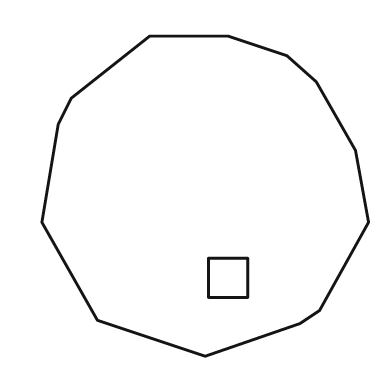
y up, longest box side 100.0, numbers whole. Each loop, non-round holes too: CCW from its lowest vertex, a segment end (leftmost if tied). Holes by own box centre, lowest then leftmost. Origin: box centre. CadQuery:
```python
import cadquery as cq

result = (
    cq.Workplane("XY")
    .moveTo(0.0, -49.0)
    .lineTo(29.0, -39.0)
    .lineTo(35.0, -35.0)
    .lineTo(50.0, -8.0)
    .lineTo(46.0, 14.0)
    .lineTo(34.0, 35.0)
    .lineTo(25.0, 43.0)
    .lineTo(7.0, 49.0)
    .lineTo(-17.0, 49.0)
    .lineTo(-41.0, 30.0)
    .lineTo(-45.0, 22.0)
    .lineTo(-50.0, -8.0)
    .lineTo(-33.0, -38.0)
    .close()
    .moveTo(1.0, -31.0)
    .lineTo(13.0, -31.0)
    .lineTo(13.0, -19.0)
    .lineTo(1.0, -19.0)
    .close()
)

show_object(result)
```